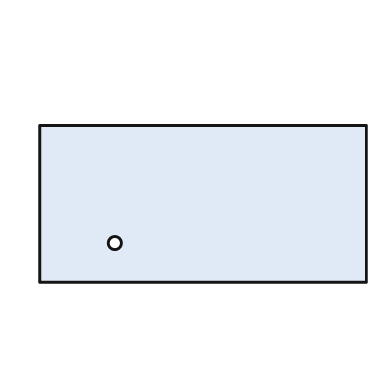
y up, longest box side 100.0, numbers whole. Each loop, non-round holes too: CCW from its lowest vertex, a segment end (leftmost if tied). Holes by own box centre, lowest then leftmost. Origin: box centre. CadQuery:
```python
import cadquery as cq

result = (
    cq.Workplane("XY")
    .moveTo(-50.0, -24.0)
    .lineTo(50.0, -24.0)
    .lineTo(50.0, 24.0)
    .lineTo(-50.0, 24.0)
    .close()
    .moveTo(-27.0, -12.0)
    .circle(2.0)
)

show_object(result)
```